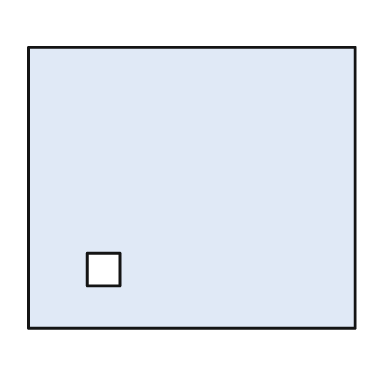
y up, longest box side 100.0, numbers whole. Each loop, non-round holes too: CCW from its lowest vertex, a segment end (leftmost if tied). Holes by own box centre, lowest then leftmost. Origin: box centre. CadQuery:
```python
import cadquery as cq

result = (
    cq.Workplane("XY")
    .moveTo(-50.0, -43.0)
    .lineTo(50.0, -43.0)
    .lineTo(50.0, 43.0)
    .lineTo(-50.0, 43.0)
    .close()
    .moveTo(-32.0, -30.0)
    .lineTo(-22.0, -30.0)
    .lineTo(-22.0, -20.0)
    .lineTo(-32.0, -20.0)
    .close()
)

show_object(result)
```